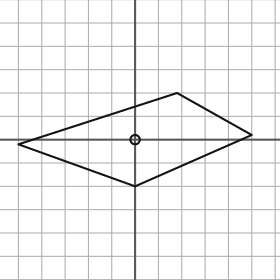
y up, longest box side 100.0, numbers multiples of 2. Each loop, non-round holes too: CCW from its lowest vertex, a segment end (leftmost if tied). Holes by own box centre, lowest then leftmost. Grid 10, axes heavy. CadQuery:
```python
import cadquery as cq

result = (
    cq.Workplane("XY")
    .moveTo(0.0, -20.0)
    .lineTo(50.0, 2.0)
    .lineTo(18.0, 20.0)
    .lineTo(-50.0, -2.0)
    .close()
    .moveTo(0.0, 0.0)
    .circle(2.0)
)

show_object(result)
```